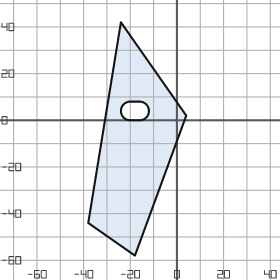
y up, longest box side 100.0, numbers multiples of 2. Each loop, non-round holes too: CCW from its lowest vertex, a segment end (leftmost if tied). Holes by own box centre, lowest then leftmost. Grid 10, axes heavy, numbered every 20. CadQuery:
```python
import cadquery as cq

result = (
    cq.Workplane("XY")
    .moveTo(-18.0, -58.0)
    .lineTo(4.0, 2.0)
    .lineTo(-24.0, 42.0)
    .lineTo(-38.0, -44.0)
    .close()
    .moveTo(-20.0, 0.0)
    .lineTo(-16.0, 0.0)
    .threePointArc((-12.0, 4.0), (-16.0, 8.0))
    .lineTo(-20.0, 8.0)
    .threePointArc((-24.0, 4.0), (-20.0, 0.0))
    .close()
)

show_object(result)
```